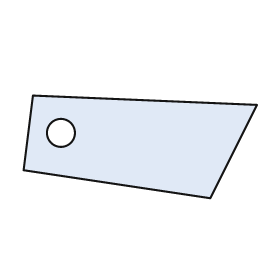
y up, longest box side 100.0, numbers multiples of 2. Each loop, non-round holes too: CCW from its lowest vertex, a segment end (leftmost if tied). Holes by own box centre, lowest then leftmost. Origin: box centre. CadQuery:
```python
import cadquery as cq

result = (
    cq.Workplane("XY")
    .moveTo(30.0, -22.0)
    .lineTo(50.0, 18.0)
    .lineTo(-46.0, 22.0)
    .lineTo(-50.0, -10.0)
    .close()
    .moveTo(-34.0, 6.0)
    .circle(6.0)
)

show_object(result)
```